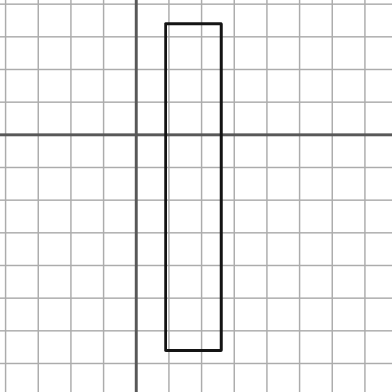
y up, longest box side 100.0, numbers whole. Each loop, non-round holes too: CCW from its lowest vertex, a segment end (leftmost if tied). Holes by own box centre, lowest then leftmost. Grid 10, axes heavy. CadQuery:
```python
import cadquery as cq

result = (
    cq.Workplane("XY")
    .moveTo(9.0, -66.0)
    .lineTo(26.0, -66.0)
    .lineTo(26.0, 34.0)
    .lineTo(9.0, 34.0)
    .close()
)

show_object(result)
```